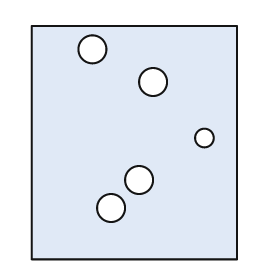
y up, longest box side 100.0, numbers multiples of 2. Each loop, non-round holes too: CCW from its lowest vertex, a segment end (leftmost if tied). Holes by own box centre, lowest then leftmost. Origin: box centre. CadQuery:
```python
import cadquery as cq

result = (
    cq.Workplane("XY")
    .moveTo(-44.0, -50.0)
    .lineTo(44.0, -50.0)
    .lineTo(44.0, 50.0)
    .lineTo(-44.0, 50.0)
    .close()
    .moveTo(-10.0, -28.0)
    .circle(6.0)
    .moveTo(2.0, -16.0)
    .circle(6.0)
    .moveTo(30.0, 2.0)
    .circle(4.0)
    .moveTo(8.0, 26.0)
    .circle(6.0)
    .moveTo(-18.0, 40.0)
    .circle(6.0)
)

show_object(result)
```